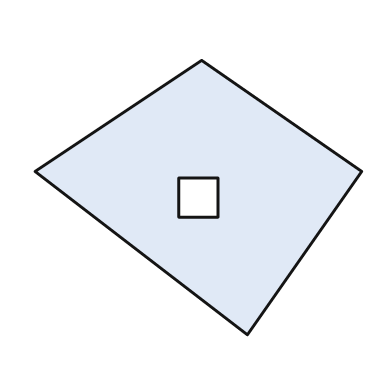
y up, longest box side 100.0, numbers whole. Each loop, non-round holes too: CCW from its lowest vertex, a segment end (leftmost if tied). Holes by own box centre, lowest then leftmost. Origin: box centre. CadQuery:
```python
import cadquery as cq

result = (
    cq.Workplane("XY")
    .moveTo(15.0, -42.0)
    .lineTo(50.0, 8.0)
    .lineTo(1.0, 42.0)
    .lineTo(-50.0, 8.0)
    .close()
    .moveTo(-6.0, -6.0)
    .lineTo(6.0, -6.0)
    .lineTo(6.0, 6.0)
    .lineTo(-6.0, 6.0)
    .close()
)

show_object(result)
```